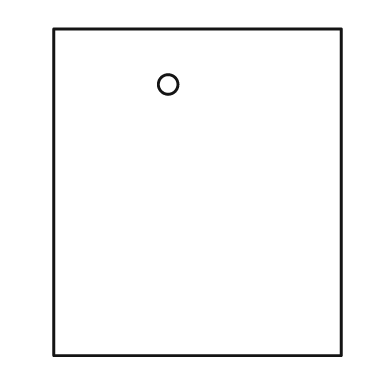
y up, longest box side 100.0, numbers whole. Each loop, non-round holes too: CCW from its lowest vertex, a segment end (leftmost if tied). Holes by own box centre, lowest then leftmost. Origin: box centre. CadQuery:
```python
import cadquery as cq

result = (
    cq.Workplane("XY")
    .moveTo(-44.0, -50.0)
    .lineTo(44.0, -50.0)
    .lineTo(44.0, 50.0)
    .lineTo(-44.0, 50.0)
    .close()
    .moveTo(-9.0, 33.0)
    .circle(3.0)
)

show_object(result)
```